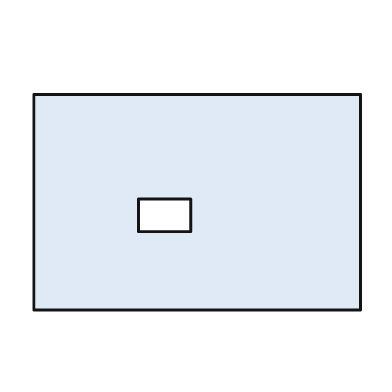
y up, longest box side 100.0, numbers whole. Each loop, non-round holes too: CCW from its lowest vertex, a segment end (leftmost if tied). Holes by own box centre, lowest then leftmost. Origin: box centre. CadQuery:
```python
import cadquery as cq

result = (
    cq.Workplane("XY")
    .moveTo(-50.0, -33.0)
    .lineTo(50.0, -33.0)
    .lineTo(50.0, 33.0)
    .lineTo(-50.0, 33.0)
    .close()
    .moveTo(-18.0, -9.0)
    .lineTo(-2.0, -9.0)
    .lineTo(-2.0, 1.0)
    .lineTo(-18.0, 1.0)
    .close()
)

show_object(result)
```